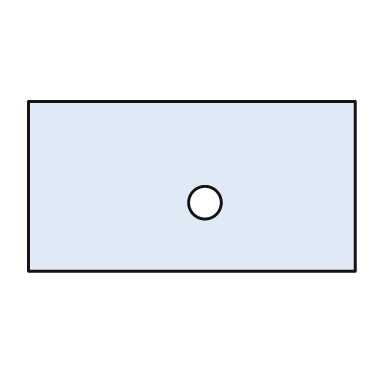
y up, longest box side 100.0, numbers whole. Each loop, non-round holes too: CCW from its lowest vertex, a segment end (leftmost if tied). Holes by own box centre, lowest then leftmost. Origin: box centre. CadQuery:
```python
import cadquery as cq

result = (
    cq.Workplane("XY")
    .moveTo(-50.0, -26.0)
    .lineTo(50.0, -26.0)
    .lineTo(50.0, 26.0)
    .lineTo(-50.0, 26.0)
    .close()
    .moveTo(4.0, -5.0)
    .circle(5.0)
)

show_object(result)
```